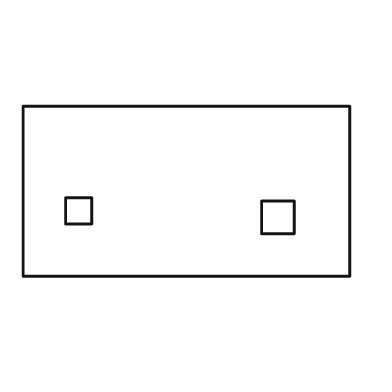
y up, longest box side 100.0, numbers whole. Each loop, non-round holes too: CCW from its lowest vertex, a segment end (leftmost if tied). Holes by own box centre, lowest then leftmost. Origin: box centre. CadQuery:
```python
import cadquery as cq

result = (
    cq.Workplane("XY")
    .moveTo(-50.0, -26.0)
    .lineTo(50.0, -26.0)
    .lineTo(50.0, 26.0)
    .lineTo(-50.0, 26.0)
    .close()
    .moveTo(23.0, -13.0)
    .lineTo(33.0, -13.0)
    .lineTo(33.0, -3.0)
    .lineTo(23.0, -3.0)
    .close()
    .moveTo(-37.0, -10.0)
    .lineTo(-29.0, -10.0)
    .lineTo(-29.0, -2.0)
    .lineTo(-37.0, -2.0)
    .close()
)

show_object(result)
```